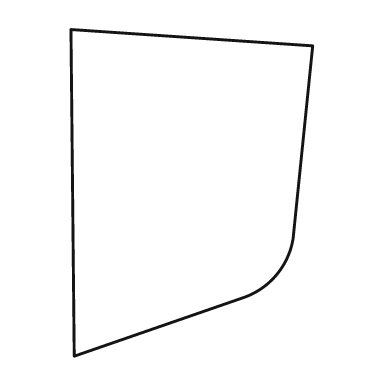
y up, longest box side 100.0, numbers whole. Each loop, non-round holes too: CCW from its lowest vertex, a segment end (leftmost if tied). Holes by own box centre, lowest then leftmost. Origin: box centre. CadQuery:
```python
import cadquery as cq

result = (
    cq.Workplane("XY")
    .moveTo(-36.0, -50.0)
    .lineTo(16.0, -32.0)
    .threePointArc((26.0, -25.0), (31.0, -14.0))
    .lineTo(37.0, 45.0)
    .lineTo(-37.0, 50.0)
    .close()
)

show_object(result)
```